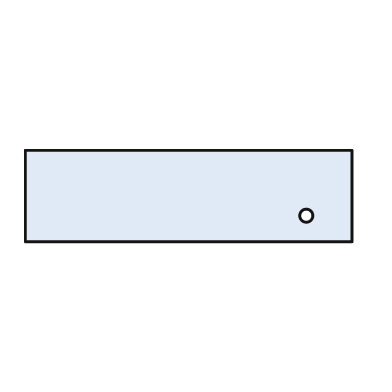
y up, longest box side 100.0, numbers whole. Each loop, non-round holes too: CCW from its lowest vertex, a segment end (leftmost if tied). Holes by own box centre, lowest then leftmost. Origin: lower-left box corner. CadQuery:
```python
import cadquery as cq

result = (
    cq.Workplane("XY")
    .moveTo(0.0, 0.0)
    .lineTo(100.0, 0.0)
    .lineTo(100.0, 28.0)
    .lineTo(0.0, 28.0)
    .close()
    .moveTo(86.0, 8.0)
    .circle(2.0)
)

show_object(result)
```